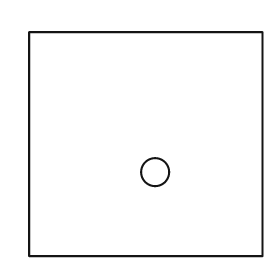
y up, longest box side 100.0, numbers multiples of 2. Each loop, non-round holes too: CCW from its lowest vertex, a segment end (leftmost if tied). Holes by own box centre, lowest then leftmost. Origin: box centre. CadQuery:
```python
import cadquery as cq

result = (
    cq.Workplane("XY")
    .moveTo(-50.0, -48.0)
    .lineTo(50.0, -48.0)
    .lineTo(50.0, 48.0)
    .lineTo(-50.0, 48.0)
    .close()
    .moveTo(4.0, -12.0)
    .circle(6.0)
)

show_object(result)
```